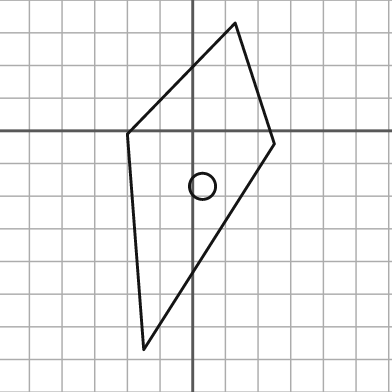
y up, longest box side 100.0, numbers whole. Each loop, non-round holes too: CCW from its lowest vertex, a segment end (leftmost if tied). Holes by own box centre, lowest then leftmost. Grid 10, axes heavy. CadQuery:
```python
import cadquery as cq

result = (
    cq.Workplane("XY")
    .moveTo(-15.0, -67.0)
    .lineTo(25.0, -4.0)
    .lineTo(13.0, 33.0)
    .lineTo(-20.0, -1.0)
    .close()
    .moveTo(3.0, -17.0)
    .circle(4.0)
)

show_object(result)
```